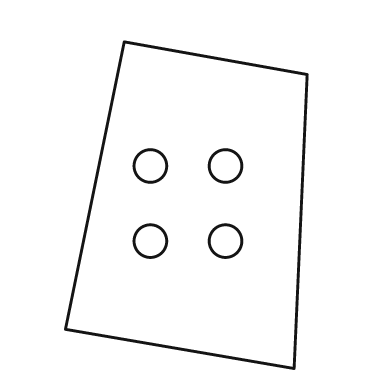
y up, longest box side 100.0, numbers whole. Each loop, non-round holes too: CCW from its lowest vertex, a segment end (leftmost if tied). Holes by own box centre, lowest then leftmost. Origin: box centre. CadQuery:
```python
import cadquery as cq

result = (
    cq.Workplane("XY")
    .moveTo(33.0, -50.0)
    .lineTo(37.0, 40.0)
    .lineTo(-19.0, 50.0)
    .lineTo(-37.0, -38.0)
    .close()
    .moveTo(-11.0, -11.0)
    .circle(5.0)
    .moveTo(12.0, -11.0)
    .circle(5.0)
    .moveTo(-11.0, 12.0)
    .circle(5.0)
    .moveTo(12.0, 12.0)
    .circle(5.0)
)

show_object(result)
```